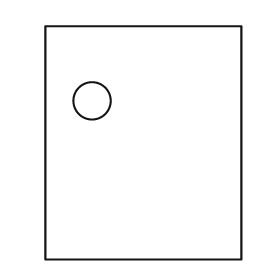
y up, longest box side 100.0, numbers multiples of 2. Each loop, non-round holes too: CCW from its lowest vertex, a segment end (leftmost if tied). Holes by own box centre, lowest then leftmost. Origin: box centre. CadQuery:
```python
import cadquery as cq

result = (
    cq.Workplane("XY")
    .moveTo(-42.0, -50.0)
    .lineTo(42.0, -50.0)
    .lineTo(42.0, 50.0)
    .lineTo(-42.0, 50.0)
    .close()
    .moveTo(-22.0, 18.0)
    .circle(8.0)
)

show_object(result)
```